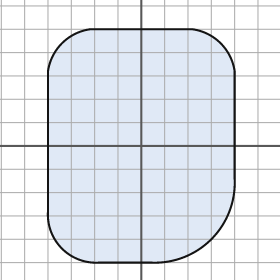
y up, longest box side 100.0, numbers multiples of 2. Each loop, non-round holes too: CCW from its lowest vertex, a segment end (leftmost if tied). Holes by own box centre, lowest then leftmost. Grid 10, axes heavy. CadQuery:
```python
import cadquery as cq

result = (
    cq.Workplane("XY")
    .moveTo(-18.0, -50.0)
    .lineTo(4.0, -50.0)
    .threePointArc((30.0, -40.0), (40.0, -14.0))
    .lineTo(40.0, 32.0)
    .threePointArc((34.0, 44.0), (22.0, 50.0))
    .lineTo(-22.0, 50.0)
    .threePointArc((-34.0, 44.0), (-40.0, 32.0))
    .lineTo(-40.0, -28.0)
    .threePointArc((-34.0, -44.0), (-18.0, -50.0))
    .close()
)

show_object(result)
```